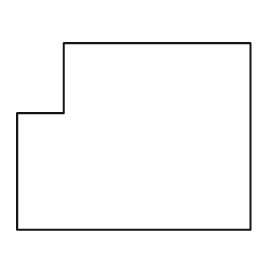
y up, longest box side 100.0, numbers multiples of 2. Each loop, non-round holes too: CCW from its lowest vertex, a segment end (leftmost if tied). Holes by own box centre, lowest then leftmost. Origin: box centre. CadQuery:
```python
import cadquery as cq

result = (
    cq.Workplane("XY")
    .moveTo(-50.0, -40.0)
    .lineTo(50.0, -40.0)
    .lineTo(50.0, 40.0)
    .lineTo(-30.0, 40.0)
    .lineTo(-30.0, 10.0)
    .lineTo(-50.0, 10.0)
    .close()
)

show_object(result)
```